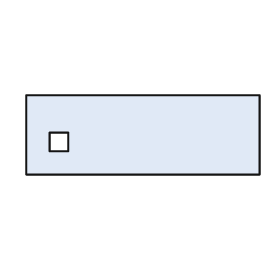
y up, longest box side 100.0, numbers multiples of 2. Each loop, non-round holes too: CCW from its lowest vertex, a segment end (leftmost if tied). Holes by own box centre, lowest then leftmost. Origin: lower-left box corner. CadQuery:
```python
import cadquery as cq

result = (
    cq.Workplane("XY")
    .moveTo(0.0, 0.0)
    .lineTo(100.0, 0.0)
    .lineTo(100.0, 34.0)
    .lineTo(0.0, 34.0)
    .close()
    .moveTo(10.0, 10.0)
    .lineTo(18.0, 10.0)
    .lineTo(18.0, 18.0)
    .lineTo(10.0, 18.0)
    .close()
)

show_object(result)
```